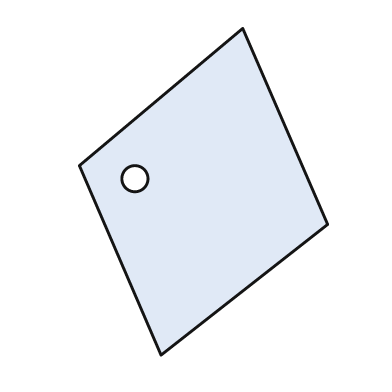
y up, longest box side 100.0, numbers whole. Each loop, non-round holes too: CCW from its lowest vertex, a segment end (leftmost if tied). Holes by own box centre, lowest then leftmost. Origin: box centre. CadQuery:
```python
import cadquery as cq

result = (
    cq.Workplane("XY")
    .moveTo(-13.0, -50.0)
    .lineTo(38.0, -10.0)
    .lineTo(12.0, 50.0)
    .lineTo(-38.0, 8.0)
    .close()
    .moveTo(-21.0, 4.0)
    .circle(4.0)
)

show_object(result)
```